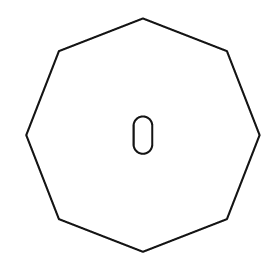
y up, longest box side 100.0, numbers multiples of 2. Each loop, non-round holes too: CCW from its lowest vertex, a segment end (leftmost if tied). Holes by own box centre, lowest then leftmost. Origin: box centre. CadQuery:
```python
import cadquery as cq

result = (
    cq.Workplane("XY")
    .moveTo(0.0, -50.0)
    .lineTo(36.0, -36.0)
    .lineTo(50.0, 0.0)
    .lineTo(36.0, 36.0)
    .lineTo(0.0, 50.0)
    .lineTo(-36.0, 36.0)
    .lineTo(-50.0, 0.0)
    .lineTo(-36.0, -36.0)
    .close()
    .moveTo(-4.0, -4.0)
    .threePointArc((0.0, -8.0), (4.0, -4.0))
    .lineTo(4.0, 4.0)
    .threePointArc((0.0, 8.0), (-4.0, 4.0))
    .close()
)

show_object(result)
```